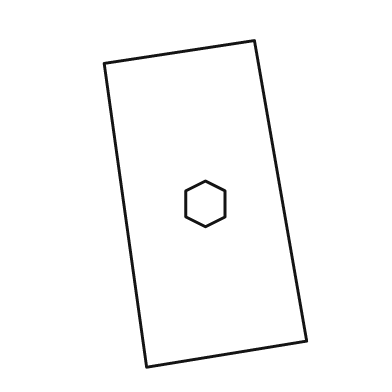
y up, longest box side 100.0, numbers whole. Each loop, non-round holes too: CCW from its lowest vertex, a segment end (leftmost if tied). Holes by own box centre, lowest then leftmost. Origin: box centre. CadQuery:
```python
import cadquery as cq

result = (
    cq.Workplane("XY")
    .moveTo(-18.0, -50.0)
    .lineTo(31.0, -42.0)
    .lineTo(15.0, 50.0)
    .lineTo(-31.0, 43.0)
    .close()
    .moveTo(0.0, -7.0)
    .lineTo(6.0, -4.0)
    .lineTo(6.0, 4.0)
    .lineTo(0.0, 7.0)
    .lineTo(-6.0, 4.0)
    .lineTo(-6.0, -4.0)
    .close()
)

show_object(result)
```